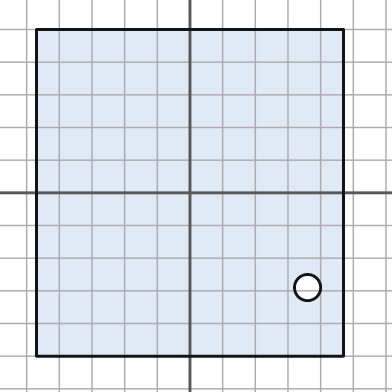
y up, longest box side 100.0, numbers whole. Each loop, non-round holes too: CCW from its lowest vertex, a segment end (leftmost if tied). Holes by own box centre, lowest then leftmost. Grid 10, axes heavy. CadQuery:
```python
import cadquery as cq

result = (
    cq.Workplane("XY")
    .moveTo(-47.0, -50.0)
    .lineTo(47.0, -50.0)
    .lineTo(47.0, 50.0)
    .lineTo(-47.0, 50.0)
    .close()
    .moveTo(36.0, -29.0)
    .circle(4.0)
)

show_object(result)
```